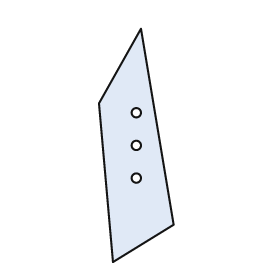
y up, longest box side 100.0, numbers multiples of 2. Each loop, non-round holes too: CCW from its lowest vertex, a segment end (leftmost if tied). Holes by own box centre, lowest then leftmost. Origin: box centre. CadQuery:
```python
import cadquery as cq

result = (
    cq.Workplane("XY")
    .moveTo(-10.0, -50.0)
    .lineTo(16.0, -34.0)
    .lineTo(2.0, 50.0)
    .lineTo(-16.0, 18.0)
    .close()
    .moveTo(0.0, -14.0)
    .circle(2.0)
    .moveTo(0.0, 0.0)
    .circle(2.0)
    .moveTo(0.0, 14.0)
    .circle(2.0)
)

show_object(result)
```